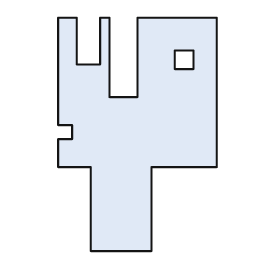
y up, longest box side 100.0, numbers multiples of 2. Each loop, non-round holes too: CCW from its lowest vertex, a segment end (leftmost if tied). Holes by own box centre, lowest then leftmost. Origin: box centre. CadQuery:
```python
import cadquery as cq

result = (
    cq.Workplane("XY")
    .moveTo(-20.0, -50.0)
    .lineTo(6.0, -50.0)
    .lineTo(6.0, -14.0)
    .lineTo(34.0, -14.0)
    .lineTo(34.0, 50.0)
    .lineTo(0.0, 50.0)
    .lineTo(0.0, 16.0)
    .lineTo(-12.0, 16.0)
    .lineTo(-12.0, 50.0)
    .lineTo(-16.0, 50.0)
    .lineTo(-16.0, 30.0)
    .lineTo(-26.0, 30.0)
    .lineTo(-26.0, 50.0)
    .lineTo(-34.0, 50.0)
    .lineTo(-34.0, 4.0)
    .lineTo(-28.0, 4.0)
    .lineTo(-28.0, -2.0)
    .lineTo(-34.0, -2.0)
    .lineTo(-34.0, -14.0)
    .lineTo(-20.0, -14.0)
    .close()
    .moveTo(16.0, 28.0)
    .lineTo(24.0, 28.0)
    .lineTo(24.0, 36.0)
    .lineTo(16.0, 36.0)
    .close()
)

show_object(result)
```